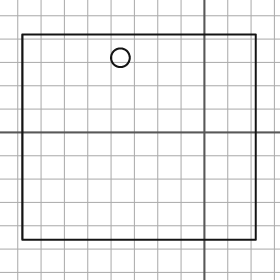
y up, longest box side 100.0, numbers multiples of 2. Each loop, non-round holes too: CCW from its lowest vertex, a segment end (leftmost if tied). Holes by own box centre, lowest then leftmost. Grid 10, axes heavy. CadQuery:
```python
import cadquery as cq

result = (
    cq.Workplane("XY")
    .moveTo(-78.0, -46.0)
    .lineTo(22.0, -46.0)
    .lineTo(22.0, 42.0)
    .lineTo(-78.0, 42.0)
    .close()
    .moveTo(-36.0, 32.0)
    .circle(4.0)
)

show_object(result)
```